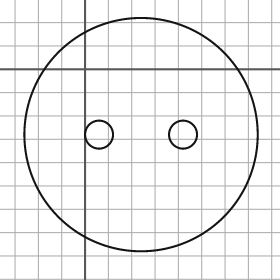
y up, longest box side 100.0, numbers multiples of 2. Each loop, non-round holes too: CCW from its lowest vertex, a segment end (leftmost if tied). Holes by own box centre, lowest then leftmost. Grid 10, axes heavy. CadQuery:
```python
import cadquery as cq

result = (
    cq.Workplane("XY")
    .moveTo(24.0, -28.0)
    .circle(50.0)
    .moveTo(6.0, -28.0)
    .circle(6.0)
    .moveTo(42.0, -28.0)
    .circle(6.0)
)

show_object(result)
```